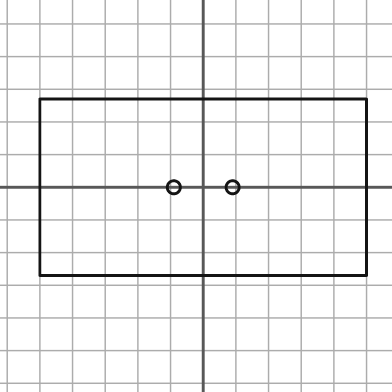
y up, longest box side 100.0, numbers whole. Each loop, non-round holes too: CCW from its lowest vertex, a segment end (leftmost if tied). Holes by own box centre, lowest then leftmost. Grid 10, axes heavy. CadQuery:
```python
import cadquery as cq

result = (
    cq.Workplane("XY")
    .moveTo(-50.0, -27.0)
    .lineTo(50.0, -27.0)
    .lineTo(50.0, 27.0)
    .lineTo(-50.0, 27.0)
    .close()
    .moveTo(-9.0, 0.0)
    .circle(2.0)
    .moveTo(9.0, 0.0)
    .circle(2.0)
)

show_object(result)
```